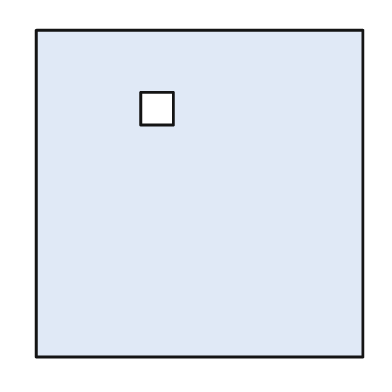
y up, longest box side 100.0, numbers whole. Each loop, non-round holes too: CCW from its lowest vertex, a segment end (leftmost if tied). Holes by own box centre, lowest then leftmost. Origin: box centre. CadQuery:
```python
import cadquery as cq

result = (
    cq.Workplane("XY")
    .moveTo(-50.0, -50.0)
    .lineTo(50.0, -50.0)
    .lineTo(50.0, 50.0)
    .lineTo(-50.0, 50.0)
    .close()
    .moveTo(-18.0, 21.0)
    .lineTo(-8.0, 21.0)
    .lineTo(-8.0, 31.0)
    .lineTo(-18.0, 31.0)
    .close()
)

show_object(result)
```